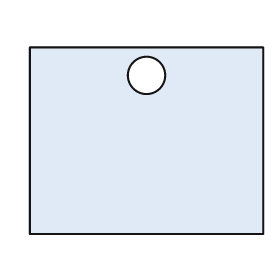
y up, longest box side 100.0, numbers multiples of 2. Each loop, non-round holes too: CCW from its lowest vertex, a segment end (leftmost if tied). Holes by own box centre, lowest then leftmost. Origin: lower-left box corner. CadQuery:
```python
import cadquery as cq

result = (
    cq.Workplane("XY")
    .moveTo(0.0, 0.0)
    .lineTo(100.0, 0.0)
    .lineTo(100.0, 80.0)
    .lineTo(0.0, 80.0)
    .close()
    .moveTo(50.0, 68.0)
    .circle(8.0)
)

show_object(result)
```